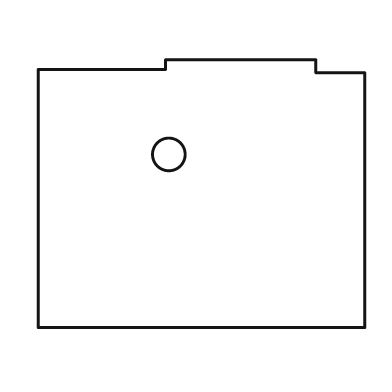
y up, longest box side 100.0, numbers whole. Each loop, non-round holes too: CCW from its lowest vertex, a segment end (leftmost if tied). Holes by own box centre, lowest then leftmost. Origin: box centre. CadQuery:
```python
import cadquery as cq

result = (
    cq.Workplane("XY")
    .moveTo(-50.0, -41.0)
    .lineTo(50.0, -41.0)
    .lineTo(50.0, 37.0)
    .lineTo(35.0, 37.0)
    .lineTo(35.0, 41.0)
    .lineTo(-11.0, 41.0)
    .lineTo(-11.0, 38.0)
    .lineTo(-50.0, 38.0)
    .close()
    .moveTo(-10.0, 12.0)
    .circle(5.0)
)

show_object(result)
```